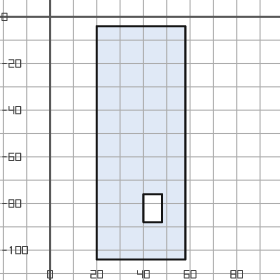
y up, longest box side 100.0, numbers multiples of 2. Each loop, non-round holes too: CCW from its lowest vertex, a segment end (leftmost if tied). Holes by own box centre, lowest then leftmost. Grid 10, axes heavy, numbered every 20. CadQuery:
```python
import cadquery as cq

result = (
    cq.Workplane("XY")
    .moveTo(20.0, -104.0)
    .lineTo(58.0, -104.0)
    .lineTo(58.0, -4.0)
    .lineTo(20.0, -4.0)
    .close()
    .moveTo(40.0, -88.0)
    .lineTo(48.0, -88.0)
    .lineTo(48.0, -76.0)
    .lineTo(40.0, -76.0)
    .close()
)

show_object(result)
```